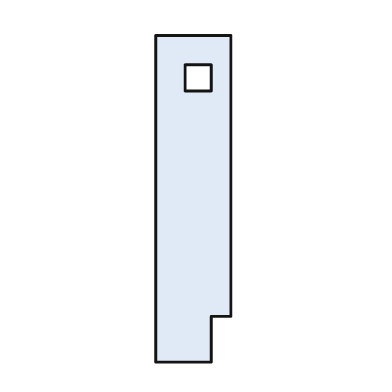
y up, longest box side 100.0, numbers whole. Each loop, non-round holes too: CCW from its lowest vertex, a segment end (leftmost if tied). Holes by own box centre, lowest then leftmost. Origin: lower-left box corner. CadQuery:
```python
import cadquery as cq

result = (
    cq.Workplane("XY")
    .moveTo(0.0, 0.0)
    .lineTo(17.0, 0.0)
    .lineTo(17.0, 14.0)
    .lineTo(23.0, 14.0)
    .lineTo(23.0, 100.0)
    .lineTo(0.0, 100.0)
    .close()
    .moveTo(9.0, 83.0)
    .lineTo(17.0, 83.0)
    .lineTo(17.0, 91.0)
    .lineTo(9.0, 91.0)
    .close()
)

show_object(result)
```